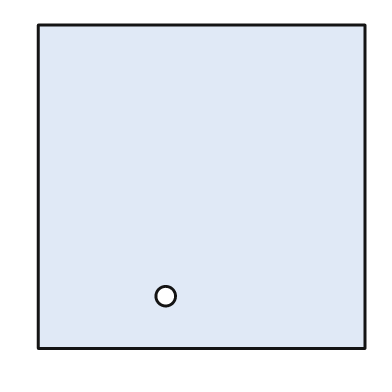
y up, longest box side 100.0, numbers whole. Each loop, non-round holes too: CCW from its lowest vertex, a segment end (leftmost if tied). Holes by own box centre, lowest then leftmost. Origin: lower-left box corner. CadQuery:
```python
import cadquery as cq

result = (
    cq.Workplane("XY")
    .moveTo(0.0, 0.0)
    .lineTo(100.0, 0.0)
    .lineTo(100.0, 99.0)
    .lineTo(0.0, 99.0)
    .close()
    .moveTo(39.0, 16.0)
    .circle(3.0)
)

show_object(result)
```